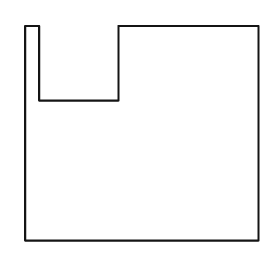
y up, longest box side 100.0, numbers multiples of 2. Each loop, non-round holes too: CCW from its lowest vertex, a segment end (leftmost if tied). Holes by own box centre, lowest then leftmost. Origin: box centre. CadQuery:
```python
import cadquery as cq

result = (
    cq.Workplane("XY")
    .moveTo(-50.0, -46.0)
    .lineTo(50.0, -46.0)
    .lineTo(50.0, 46.0)
    .lineTo(-10.0, 46.0)
    .lineTo(-10.0, 14.0)
    .lineTo(-44.0, 14.0)
    .lineTo(-44.0, 46.0)
    .lineTo(-50.0, 46.0)
    .close()
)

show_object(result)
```